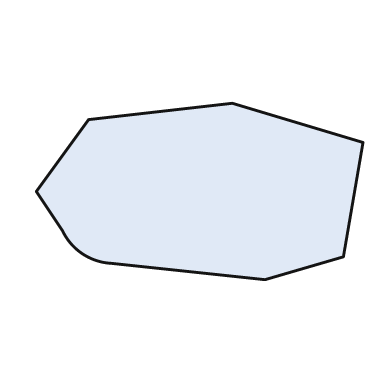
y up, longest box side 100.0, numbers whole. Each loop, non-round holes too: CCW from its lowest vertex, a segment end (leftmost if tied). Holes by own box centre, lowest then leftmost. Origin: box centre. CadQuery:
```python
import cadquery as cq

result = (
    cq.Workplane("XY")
    .moveTo(20.0, -27.0)
    .lineTo(44.0, -20.0)
    .lineTo(50.0, 15.0)
    .lineTo(10.0, 27.0)
    .lineTo(-34.0, 22.0)
    .lineTo(-50.0, 0.0)
    .lineTo(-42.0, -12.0)
    .threePointArc((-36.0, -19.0), (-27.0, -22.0))
    .close()
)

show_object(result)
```